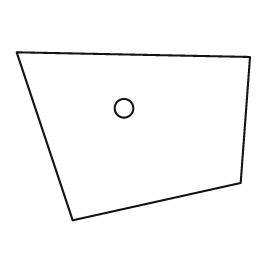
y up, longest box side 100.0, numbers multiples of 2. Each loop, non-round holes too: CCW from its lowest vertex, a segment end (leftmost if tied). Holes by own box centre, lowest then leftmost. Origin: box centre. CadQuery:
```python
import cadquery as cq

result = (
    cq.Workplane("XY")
    .moveTo(-26.0, -36.0)
    .lineTo(46.0, -20.0)
    .lineTo(50.0, 34.0)
    .lineTo(-50.0, 36.0)
    .close()
    .moveTo(-4.0, 12.0)
    .circle(4.0)
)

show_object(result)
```